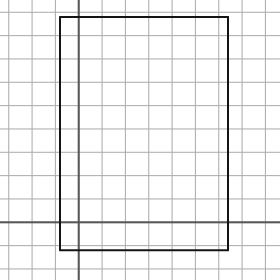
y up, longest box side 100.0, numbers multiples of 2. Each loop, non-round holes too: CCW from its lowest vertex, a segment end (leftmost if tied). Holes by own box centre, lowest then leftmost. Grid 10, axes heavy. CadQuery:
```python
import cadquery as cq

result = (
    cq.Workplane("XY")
    .moveTo(-8.0, -12.0)
    .lineTo(64.0, -12.0)
    .lineTo(64.0, 88.0)
    .lineTo(-8.0, 88.0)
    .close()
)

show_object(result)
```